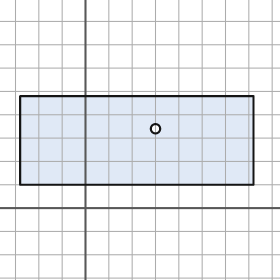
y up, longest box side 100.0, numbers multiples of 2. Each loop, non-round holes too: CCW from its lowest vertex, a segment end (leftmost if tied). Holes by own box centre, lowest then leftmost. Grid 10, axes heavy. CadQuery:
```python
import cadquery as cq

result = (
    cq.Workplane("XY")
    .moveTo(-28.0, 10.0)
    .lineTo(72.0, 10.0)
    .lineTo(72.0, 48.0)
    .lineTo(-28.0, 48.0)
    .close()
    .moveTo(30.0, 34.0)
    .circle(2.0)
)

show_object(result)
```